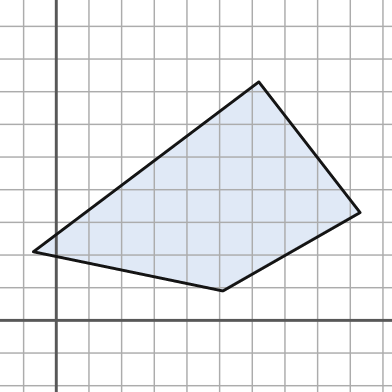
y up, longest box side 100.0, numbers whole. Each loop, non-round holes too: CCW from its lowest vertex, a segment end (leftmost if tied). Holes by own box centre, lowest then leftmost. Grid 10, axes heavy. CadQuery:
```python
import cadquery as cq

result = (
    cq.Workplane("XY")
    .moveTo(51.0, 9.0)
    .lineTo(93.0, 33.0)
    .lineTo(62.0, 73.0)
    .lineTo(-7.0, 21.0)
    .close()
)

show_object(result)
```